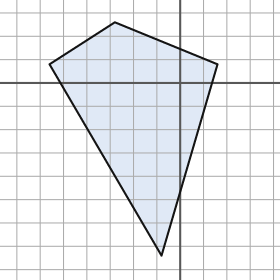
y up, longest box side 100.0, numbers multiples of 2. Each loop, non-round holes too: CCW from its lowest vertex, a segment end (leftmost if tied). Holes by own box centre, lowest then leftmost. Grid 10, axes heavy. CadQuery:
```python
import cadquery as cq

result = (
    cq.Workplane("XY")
    .moveTo(-8.0, -74.0)
    .lineTo(16.0, 8.0)
    .lineTo(-28.0, 26.0)
    .lineTo(-56.0, 8.0)
    .close()
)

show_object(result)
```